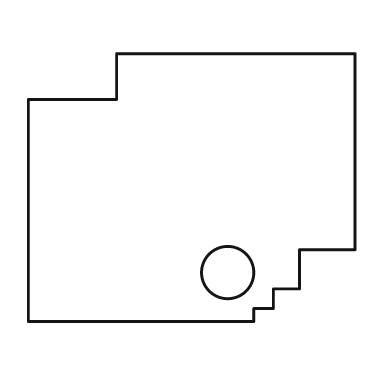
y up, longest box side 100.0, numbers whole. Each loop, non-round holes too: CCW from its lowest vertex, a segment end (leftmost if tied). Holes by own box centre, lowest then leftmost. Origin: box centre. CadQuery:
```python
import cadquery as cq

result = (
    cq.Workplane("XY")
    .moveTo(-50.0, -41.0)
    .lineTo(19.0, -41.0)
    .lineTo(19.0, -37.0)
    .lineTo(25.0, -37.0)
    .lineTo(25.0, -31.0)
    .lineTo(33.0, -31.0)
    .lineTo(33.0, -19.0)
    .lineTo(50.0, -19.0)
    .lineTo(50.0, 41.0)
    .lineTo(-23.0, 41.0)
    .lineTo(-23.0, 27.0)
    .lineTo(-50.0, 27.0)
    .close()
    .moveTo(11.0, -26.0)
    .circle(8.0)
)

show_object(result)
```